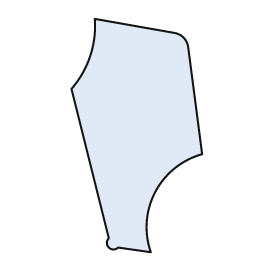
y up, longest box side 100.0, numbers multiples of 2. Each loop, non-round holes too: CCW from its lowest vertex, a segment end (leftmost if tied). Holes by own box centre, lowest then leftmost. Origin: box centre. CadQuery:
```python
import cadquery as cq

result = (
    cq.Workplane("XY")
    .moveTo(6.0, -50.0)
    .threePointArc((8.0, -24.0), (28.0, -8.0))
    .lineTo(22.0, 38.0)
    .threePointArc((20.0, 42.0), (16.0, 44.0))
    .lineTo(-18.0, 50.0)
    .threePointArc((-20.0, 34.0), (-28.0, 20.0))
    .lineTo(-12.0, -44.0)
    .threePointArc((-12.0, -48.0), (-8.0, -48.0))
    .close()
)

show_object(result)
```